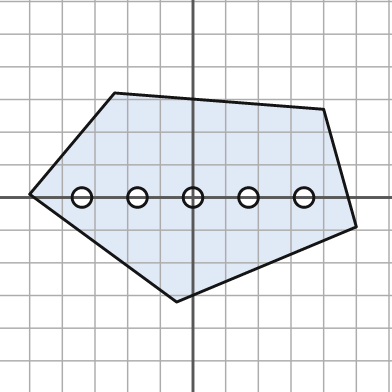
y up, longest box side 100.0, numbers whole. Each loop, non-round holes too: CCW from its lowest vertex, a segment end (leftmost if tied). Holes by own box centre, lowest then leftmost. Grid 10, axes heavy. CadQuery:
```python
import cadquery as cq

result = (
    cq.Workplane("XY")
    .moveTo(-5.0, -32.0)
    .lineTo(50.0, -9.0)
    .lineTo(40.0, 27.0)
    .lineTo(-24.0, 32.0)
    .lineTo(-50.0, 1.0)
    .close()
    .moveTo(-34.0, 0.0)
    .circle(3.0)
    .moveTo(-17.0, 0.0)
    .circle(3.0)
    .moveTo(0.0, 0.0)
    .circle(3.0)
    .moveTo(17.0, 0.0)
    .circle(3.0)
    .moveTo(34.0, 0.0)
    .circle(3.0)
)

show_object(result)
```